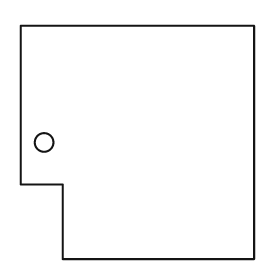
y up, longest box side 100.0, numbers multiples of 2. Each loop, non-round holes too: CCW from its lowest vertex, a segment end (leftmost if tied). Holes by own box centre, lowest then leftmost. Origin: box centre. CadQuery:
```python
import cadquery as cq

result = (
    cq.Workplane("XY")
    .moveTo(-32.0, -50.0)
    .lineTo(50.0, -50.0)
    .lineTo(50.0, 50.0)
    .lineTo(-50.0, 50.0)
    .lineTo(-50.0, -18.0)
    .lineTo(-32.0, -18.0)
    .close()
    .moveTo(-40.0, 0.0)
    .circle(4.0)
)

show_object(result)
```